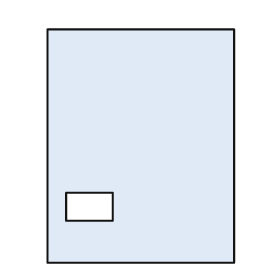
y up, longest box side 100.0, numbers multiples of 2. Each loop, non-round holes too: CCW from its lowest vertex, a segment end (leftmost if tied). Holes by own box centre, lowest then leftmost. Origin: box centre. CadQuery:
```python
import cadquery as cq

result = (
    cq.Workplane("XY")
    .moveTo(-40.0, -50.0)
    .lineTo(40.0, -50.0)
    .lineTo(40.0, 50.0)
    .lineTo(-40.0, 50.0)
    .close()
    .moveTo(-32.0, -32.0)
    .lineTo(-12.0, -32.0)
    .lineTo(-12.0, -20.0)
    .lineTo(-32.0, -20.0)
    .close()
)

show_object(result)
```